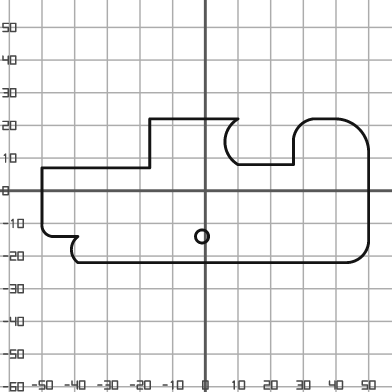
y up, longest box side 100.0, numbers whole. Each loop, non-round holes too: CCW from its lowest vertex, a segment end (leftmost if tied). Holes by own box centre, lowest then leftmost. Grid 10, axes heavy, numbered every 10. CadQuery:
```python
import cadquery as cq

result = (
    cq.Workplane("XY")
    .moveTo(-39.0, -22.0)
    .lineTo(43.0, -22.0)
    .threePointArc((48.0, -20.0), (50.0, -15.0))
    .lineTo(50.0, 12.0)
    .threePointArc((47.0, 19.0), (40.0, 22.0))
    .lineTo(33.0, 22.0)
    .threePointArc((29.0, 20.0), (27.0, 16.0))
    .lineTo(27.0, 8.0)
    .lineTo(10.0, 8.0)
    .threePointArc((6.0, 15.0), (10.0, 22.0))
    .lineTo(-17.0, 22.0)
    .lineTo(-17.0, 7.0)
    .lineTo(-50.0, 7.0)
    .lineTo(-50.0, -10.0)
    .threePointArc((-49.0, -13.0), (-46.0, -14.0))
    .lineTo(-39.0, -14.0)
    .threePointArc((-41.0, -18.0), (-39.0, -22.0))
    .close()
    .moveTo(-1.0, -14.0)
    .circle(2.0)
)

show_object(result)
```